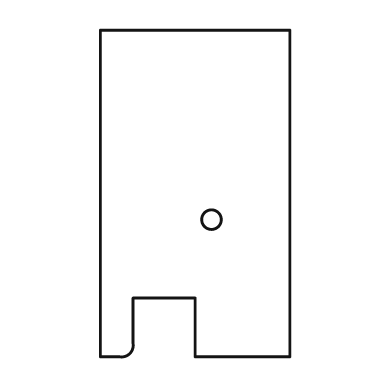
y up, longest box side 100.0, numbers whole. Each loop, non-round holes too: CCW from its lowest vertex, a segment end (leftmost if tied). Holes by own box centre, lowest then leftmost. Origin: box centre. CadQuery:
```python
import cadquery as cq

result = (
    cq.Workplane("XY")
    .moveTo(-29.0, -50.0)
    .lineTo(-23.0, -50.0)
    .threePointArc((-20.0, -49.0), (-19.0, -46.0))
    .lineTo(-19.0, -32.0)
    .lineTo(0.0, -32.0)
    .lineTo(0.0, -50.0)
    .lineTo(29.0, -50.0)
    .lineTo(29.0, 50.0)
    .lineTo(-29.0, 50.0)
    .close()
    .moveTo(5.0, -8.0)
    .circle(3.0)
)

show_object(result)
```